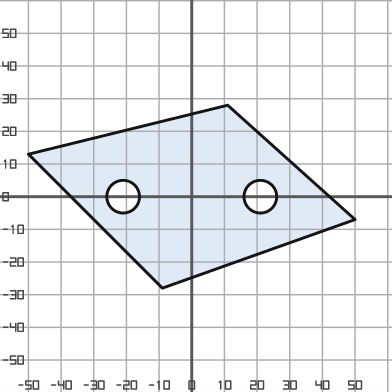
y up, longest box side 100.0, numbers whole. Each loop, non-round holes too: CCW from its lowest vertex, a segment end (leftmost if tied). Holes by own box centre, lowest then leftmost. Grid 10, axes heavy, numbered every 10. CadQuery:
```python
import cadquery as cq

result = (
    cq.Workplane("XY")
    .moveTo(-9.0, -28.0)
    .lineTo(50.0, -7.0)
    .lineTo(11.0, 28.0)
    .lineTo(-50.0, 13.0)
    .close()
    .moveTo(-21.0, 0.0)
    .circle(5.0)
    .moveTo(21.0, 0.0)
    .circle(5.0)
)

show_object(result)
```